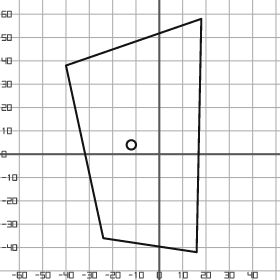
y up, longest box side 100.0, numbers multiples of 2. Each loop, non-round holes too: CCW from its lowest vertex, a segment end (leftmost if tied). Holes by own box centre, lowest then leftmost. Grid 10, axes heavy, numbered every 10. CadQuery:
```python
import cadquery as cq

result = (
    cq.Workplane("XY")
    .moveTo(16.0, -42.0)
    .lineTo(18.0, 58.0)
    .lineTo(-40.0, 38.0)
    .lineTo(-24.0, -36.0)
    .close()
    .moveTo(-12.0, 4.0)
    .circle(2.0)
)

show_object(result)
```